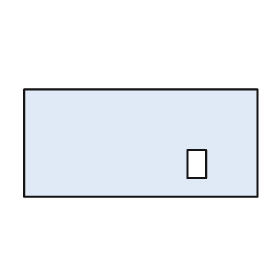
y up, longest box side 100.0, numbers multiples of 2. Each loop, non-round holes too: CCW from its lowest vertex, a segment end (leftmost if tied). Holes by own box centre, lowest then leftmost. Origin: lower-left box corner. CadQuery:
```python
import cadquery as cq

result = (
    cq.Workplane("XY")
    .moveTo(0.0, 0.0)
    .lineTo(100.0, 0.0)
    .lineTo(100.0, 46.0)
    .lineTo(0.0, 46.0)
    .close()
    .moveTo(70.0, 8.0)
    .lineTo(78.0, 8.0)
    .lineTo(78.0, 20.0)
    .lineTo(70.0, 20.0)
    .close()
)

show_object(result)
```